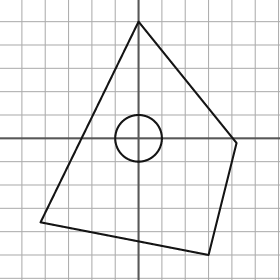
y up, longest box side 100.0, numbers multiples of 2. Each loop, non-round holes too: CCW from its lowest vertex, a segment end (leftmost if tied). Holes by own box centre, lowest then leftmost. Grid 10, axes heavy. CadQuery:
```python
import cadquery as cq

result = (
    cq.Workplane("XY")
    .moveTo(30.0, -50.0)
    .lineTo(42.0, -2.0)
    .lineTo(0.0, 50.0)
    .lineTo(-42.0, -36.0)
    .close()
    .moveTo(0.0, 0.0)
    .circle(10.0)
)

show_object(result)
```